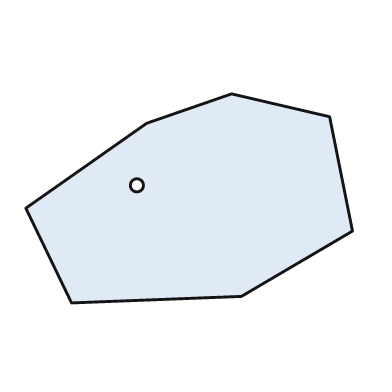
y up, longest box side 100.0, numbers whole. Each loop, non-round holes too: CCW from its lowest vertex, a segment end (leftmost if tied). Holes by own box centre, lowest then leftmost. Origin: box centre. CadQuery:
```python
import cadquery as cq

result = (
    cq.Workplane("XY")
    .moveTo(-36.0, -32.0)
    .lineTo(16.0, -30.0)
    .lineTo(50.0, -10.0)
    .lineTo(43.0, 25.0)
    .lineTo(13.0, 32.0)
    .lineTo(-13.0, 23.0)
    .lineTo(-50.0, -3.0)
    .close()
    .moveTo(-16.0, 4.0)
    .circle(2.0)
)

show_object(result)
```